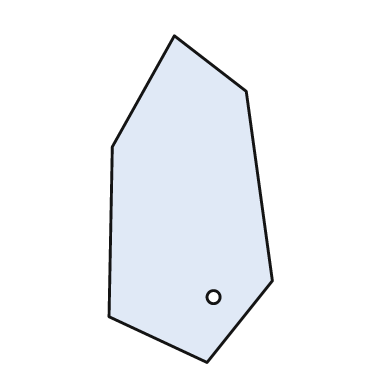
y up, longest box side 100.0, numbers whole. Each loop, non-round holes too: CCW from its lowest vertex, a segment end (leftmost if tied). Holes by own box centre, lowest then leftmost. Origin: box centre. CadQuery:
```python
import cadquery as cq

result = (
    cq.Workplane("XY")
    .moveTo(5.0, -50.0)
    .lineTo(25.0, -25.0)
    .lineTo(17.0, 33.0)
    .lineTo(-5.0, 50.0)
    .lineTo(-24.0, 16.0)
    .lineTo(-25.0, -36.0)
    .close()
    .moveTo(7.0, -30.0)
    .circle(2.0)
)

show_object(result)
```